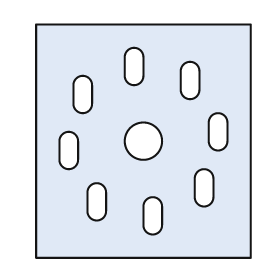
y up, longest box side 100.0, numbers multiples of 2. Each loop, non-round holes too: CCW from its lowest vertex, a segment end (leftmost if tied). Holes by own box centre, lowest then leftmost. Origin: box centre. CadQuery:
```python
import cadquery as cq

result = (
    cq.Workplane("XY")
    .moveTo(-46.0, -50.0)
    .lineTo(46.0, -50.0)
    .lineTo(46.0, 50.0)
    .lineTo(-46.0, 50.0)
    .close()
    .moveTo(0.0, -36.0)
    .threePointArc((4.0, -40.0), (8.0, -36.0))
    .lineTo(8.0, -28.0)
    .threePointArc((4.0, -24.0), (0.0, -28.0))
    .close()
    .moveTo(-24.0, -30.0)
    .threePointArc((-20.0, -34.0), (-16.0, -30.0))
    .lineTo(-16.0, -22.0)
    .threePointArc((-20.0, -18.0), (-24.0, -22.0))
    .close()
    .moveTo(22.0, -24.0)
    .threePointArc((26.0, -28.0), (30.0, -24.0))
    .lineTo(30.0, -16.0)
    .threePointArc((26.0, -12.0), (22.0, -16.0))
    .close()
    .moveTo(-36.0, -8.0)
    .threePointArc((-32.0, -12.0), (-28.0, -8.0))
    .lineTo(-28.0, 0.0)
    .threePointArc((-32.0, 4.0), (-36.0, 0.0))
    .close()
    .moveTo(0.0, 0.0)
    .circle(8.0)
    .moveTo(28.0, 0.0)
    .threePointArc((32.0, -4.0), (36.0, 0.0))
    .lineTo(36.0, 8.0)
    .threePointArc((32.0, 12.0), (28.0, 8.0))
    .close()
    .moveTo(-30.0, 16.0)
    .threePointArc((-26.0, 12.0), (-22.0, 16.0))
    .lineTo(-22.0, 24.0)
    .threePointArc((-26.0, 28.0), (-30.0, 24.0))
    .close()
    .moveTo(16.0, 22.0)
    .threePointArc((20.0, 18.0), (24.0, 22.0))
    .lineTo(24.0, 30.0)
    .threePointArc((20.0, 34.0), (16.0, 30.0))
    .close()
    .moveTo(-8.0, 28.0)
    .threePointArc((-4.0, 24.0), (0.0, 28.0))
    .lineTo(0.0, 36.0)
    .threePointArc((-4.0, 40.0), (-8.0, 36.0))
    .close()
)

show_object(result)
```